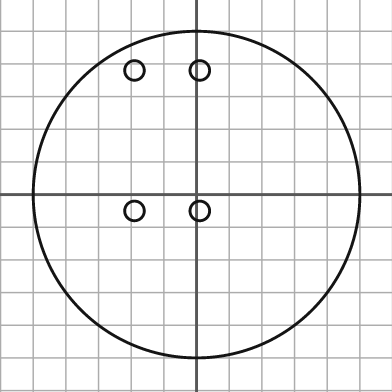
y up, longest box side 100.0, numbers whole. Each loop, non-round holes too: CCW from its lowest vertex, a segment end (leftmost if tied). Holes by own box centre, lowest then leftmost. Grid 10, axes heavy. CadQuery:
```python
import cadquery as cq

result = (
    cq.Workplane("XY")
    .moveTo(0.0, 0.0)
    .circle(50.0)
    .moveTo(-19.0, -5.0)
    .circle(3.0)
    .moveTo(1.0, -5.0)
    .circle(3.0)
    .moveTo(-19.0, 38.0)
    .circle(3.0)
    .moveTo(1.0, 38.0)
    .circle(3.0)
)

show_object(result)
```